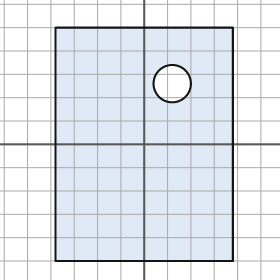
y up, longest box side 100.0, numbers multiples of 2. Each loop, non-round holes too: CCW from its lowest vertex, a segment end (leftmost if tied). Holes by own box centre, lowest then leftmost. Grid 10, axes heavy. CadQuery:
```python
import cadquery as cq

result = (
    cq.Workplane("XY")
    .moveTo(-38.0, -50.0)
    .lineTo(38.0, -50.0)
    .lineTo(38.0, 50.0)
    .lineTo(-38.0, 50.0)
    .close()
    .moveTo(12.0, 26.0)
    .circle(8.0)
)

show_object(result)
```